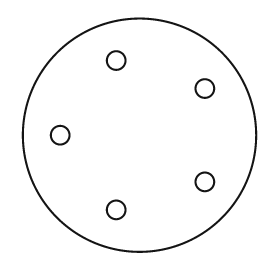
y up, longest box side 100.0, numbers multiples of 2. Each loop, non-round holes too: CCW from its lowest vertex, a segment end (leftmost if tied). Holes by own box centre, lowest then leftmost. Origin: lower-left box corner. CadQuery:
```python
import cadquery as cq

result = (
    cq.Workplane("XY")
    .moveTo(50.0, 50.0)
    .circle(50.0)
    .moveTo(40.0, 18.0)
    .circle(4.0)
    .moveTo(78.0, 30.0)
    .circle(4.0)
    .moveTo(16.0, 50.0)
    .circle(4.0)
    .moveTo(78.0, 70.0)
    .circle(4.0)
    .moveTo(40.0, 82.0)
    .circle(4.0)
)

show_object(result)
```